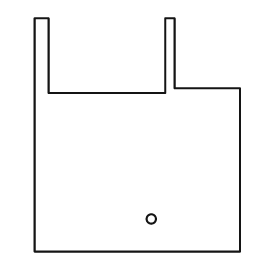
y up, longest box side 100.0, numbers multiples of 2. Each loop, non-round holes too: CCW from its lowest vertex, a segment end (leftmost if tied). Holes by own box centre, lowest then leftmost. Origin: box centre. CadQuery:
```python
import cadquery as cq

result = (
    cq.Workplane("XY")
    .moveTo(-44.0, -50.0)
    .lineTo(44.0, -50.0)
    .lineTo(44.0, 20.0)
    .lineTo(16.0, 20.0)
    .lineTo(16.0, 50.0)
    .lineTo(12.0, 50.0)
    .lineTo(12.0, 18.0)
    .lineTo(-38.0, 18.0)
    .lineTo(-38.0, 50.0)
    .lineTo(-44.0, 50.0)
    .close()
    .moveTo(6.0, -36.0)
    .circle(2.0)
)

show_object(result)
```